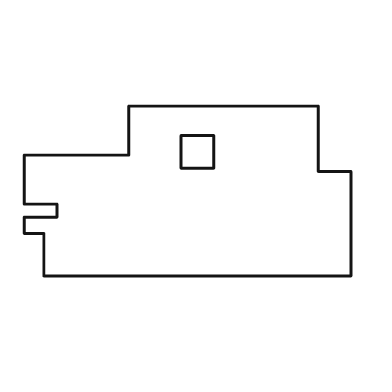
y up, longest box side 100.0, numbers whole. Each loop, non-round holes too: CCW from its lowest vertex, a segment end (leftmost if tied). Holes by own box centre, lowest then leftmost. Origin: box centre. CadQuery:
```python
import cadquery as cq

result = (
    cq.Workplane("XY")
    .moveTo(-44.0, -26.0)
    .lineTo(50.0, -26.0)
    .lineTo(50.0, 6.0)
    .lineTo(40.0, 6.0)
    .lineTo(40.0, 26.0)
    .lineTo(-18.0, 26.0)
    .lineTo(-18.0, 11.0)
    .lineTo(-50.0, 11.0)
    .lineTo(-50.0, -4.0)
    .lineTo(-40.0, -4.0)
    .lineTo(-40.0, -8.0)
    .lineTo(-50.0, -8.0)
    .lineTo(-50.0, -13.0)
    .lineTo(-44.0, -13.0)
    .close()
    .moveTo(-2.0, 7.0)
    .lineTo(8.0, 7.0)
    .lineTo(8.0, 17.0)
    .lineTo(-2.0, 17.0)
    .close()
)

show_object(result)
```